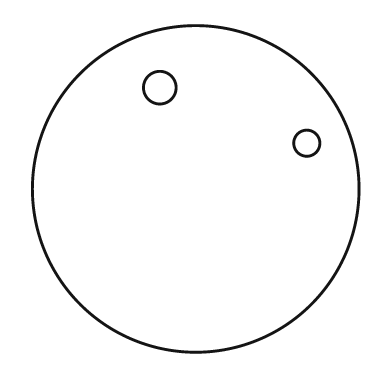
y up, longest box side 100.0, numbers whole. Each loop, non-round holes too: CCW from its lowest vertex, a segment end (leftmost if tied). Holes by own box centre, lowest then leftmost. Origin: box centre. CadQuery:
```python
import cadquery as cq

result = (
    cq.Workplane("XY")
    .moveTo(0.0, 0.0)
    .circle(50.0)
    .moveTo(34.0, 14.0)
    .circle(4.0)
    .moveTo(-11.0, 31.0)
    .circle(5.0)
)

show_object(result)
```